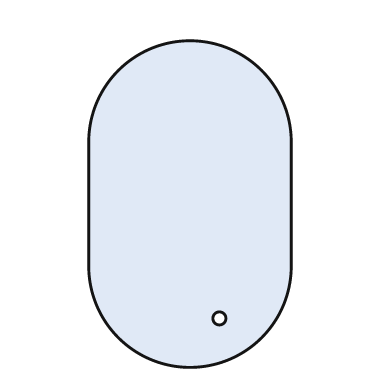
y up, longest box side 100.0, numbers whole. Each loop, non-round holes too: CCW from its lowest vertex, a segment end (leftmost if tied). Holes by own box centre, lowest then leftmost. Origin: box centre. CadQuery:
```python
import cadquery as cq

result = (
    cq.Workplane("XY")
    .moveTo(-31.0, -19.0)
    .threePointArc((0.0, -50.0), (31.0, -19.0))
    .lineTo(31.0, 19.0)
    .threePointArc((0.0, 50.0), (-31.0, 19.0))
    .close()
    .moveTo(9.0, -35.0)
    .circle(2.0)
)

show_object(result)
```